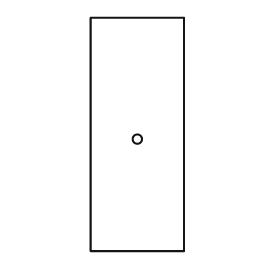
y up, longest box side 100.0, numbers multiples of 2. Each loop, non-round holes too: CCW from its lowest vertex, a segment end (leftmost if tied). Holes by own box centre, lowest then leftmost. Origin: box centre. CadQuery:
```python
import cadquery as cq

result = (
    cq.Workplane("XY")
    .moveTo(-20.0, -50.0)
    .lineTo(20.0, -50.0)
    .lineTo(20.0, 50.0)
    .lineTo(-20.0, 50.0)
    .close()
    .moveTo(0.0, -2.0)
    .circle(2.0)
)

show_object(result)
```